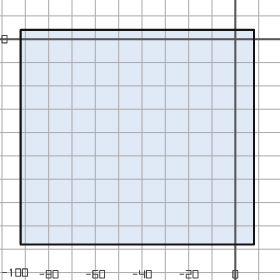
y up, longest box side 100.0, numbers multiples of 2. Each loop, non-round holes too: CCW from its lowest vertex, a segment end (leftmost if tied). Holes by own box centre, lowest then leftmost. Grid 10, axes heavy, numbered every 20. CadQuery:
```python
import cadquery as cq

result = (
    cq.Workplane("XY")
    .moveTo(-92.0, -88.0)
    .lineTo(8.0, -88.0)
    .lineTo(8.0, 4.0)
    .lineTo(-92.0, 4.0)
    .close()
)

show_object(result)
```